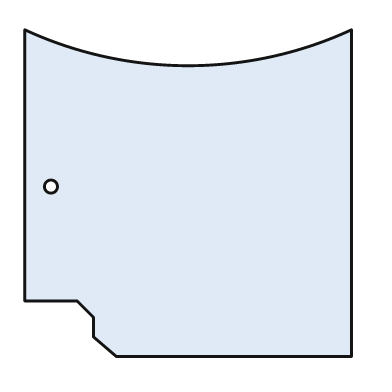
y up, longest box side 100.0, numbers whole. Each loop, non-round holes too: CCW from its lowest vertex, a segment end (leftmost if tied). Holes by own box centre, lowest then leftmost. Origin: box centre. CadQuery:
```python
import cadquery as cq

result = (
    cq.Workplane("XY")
    .moveTo(-22.0, -50.0)
    .lineTo(50.0, -50.0)
    .lineTo(50.0, 50.0)
    .threePointArc((0.0, 39.0), (-50.0, 50.0))
    .lineTo(-50.0, -33.0)
    .lineTo(-34.0, -33.0)
    .lineTo(-29.0, -38.0)
    .lineTo(-29.0, -44.0)
    .close()
    .moveTo(-42.0, 2.0)
    .circle(2.0)
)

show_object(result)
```